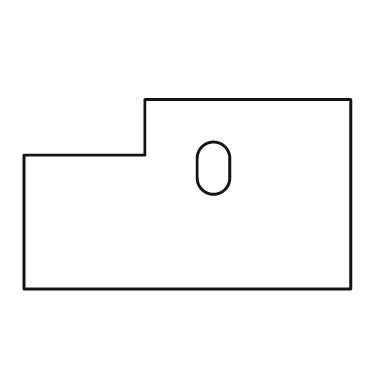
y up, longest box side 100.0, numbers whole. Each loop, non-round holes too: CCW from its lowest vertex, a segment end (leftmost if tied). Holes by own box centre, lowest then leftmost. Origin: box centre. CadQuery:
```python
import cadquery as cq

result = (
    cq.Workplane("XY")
    .moveTo(-50.0, -29.0)
    .lineTo(50.0, -29.0)
    .lineTo(50.0, 29.0)
    .lineTo(-13.0, 29.0)
    .lineTo(-13.0, 12.0)
    .lineTo(-50.0, 12.0)
    .close()
    .moveTo(3.0, 5.0)
    .threePointArc((8.0, 0.0), (13.0, 5.0))
    .lineTo(13.0, 11.0)
    .threePointArc((8.0, 16.0), (3.0, 11.0))
    .close()
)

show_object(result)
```